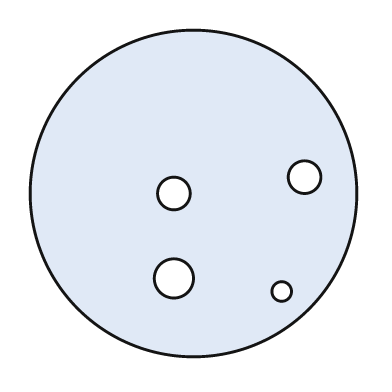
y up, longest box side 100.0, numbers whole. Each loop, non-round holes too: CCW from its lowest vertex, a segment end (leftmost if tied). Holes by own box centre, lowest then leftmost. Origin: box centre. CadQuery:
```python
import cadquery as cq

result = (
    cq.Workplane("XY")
    .moveTo(0.0, 0.0)
    .circle(50.0)
    .moveTo(27.0, -30.0)
    .circle(3.0)
    .moveTo(-6.0, -26.0)
    .circle(6.0)
    .moveTo(-6.0, 0.0)
    .circle(5.0)
    .moveTo(34.0, 5.0)
    .circle(5.0)
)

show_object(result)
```